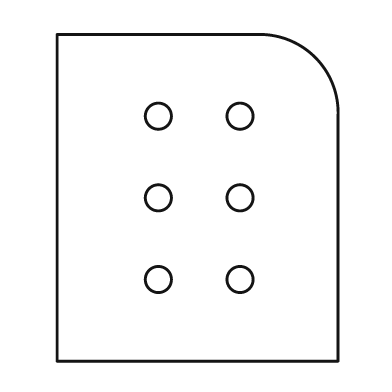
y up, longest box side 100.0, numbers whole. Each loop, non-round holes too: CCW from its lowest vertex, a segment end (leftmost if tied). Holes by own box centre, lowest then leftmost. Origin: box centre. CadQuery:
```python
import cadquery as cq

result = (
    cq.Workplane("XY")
    .moveTo(-43.0, -50.0)
    .lineTo(43.0, -50.0)
    .lineTo(43.0, 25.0)
    .threePointArc((36.0, 43.0), (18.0, 50.0))
    .lineTo(-43.0, 50.0)
    .close()
    .moveTo(-12.0, -25.0)
    .circle(4.0)
    .moveTo(13.0, -25.0)
    .circle(4.0)
    .moveTo(-12.0, 0.0)
    .circle(4.0)
    .moveTo(13.0, 0.0)
    .circle(4.0)
    .moveTo(-12.0, 25.0)
    .circle(4.0)
    .moveTo(13.0, 25.0)
    .circle(4.0)
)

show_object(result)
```